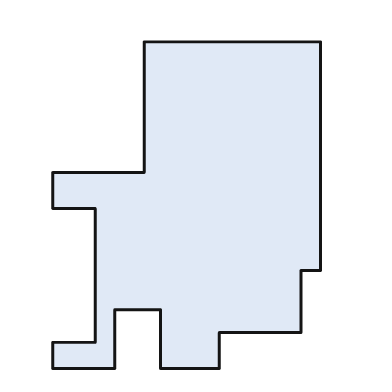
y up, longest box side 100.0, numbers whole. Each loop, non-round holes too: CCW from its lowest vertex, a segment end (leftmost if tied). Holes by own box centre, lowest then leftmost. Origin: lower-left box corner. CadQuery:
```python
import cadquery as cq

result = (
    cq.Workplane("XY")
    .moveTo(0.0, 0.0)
    .lineTo(19.0, 0.0)
    .lineTo(19.0, 18.0)
    .lineTo(33.0, 18.0)
    .lineTo(33.0, 0.0)
    .lineTo(51.0, 0.0)
    .lineTo(51.0, 11.0)
    .lineTo(76.0, 11.0)
    .lineTo(76.0, 30.0)
    .lineTo(82.0, 30.0)
    .lineTo(82.0, 100.0)
    .lineTo(28.0, 100.0)
    .lineTo(28.0, 60.0)
    .lineTo(0.0, 60.0)
    .lineTo(0.0, 49.0)
    .lineTo(13.0, 49.0)
    .lineTo(13.0, 8.0)
    .lineTo(0.0, 8.0)
    .close()
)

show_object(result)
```